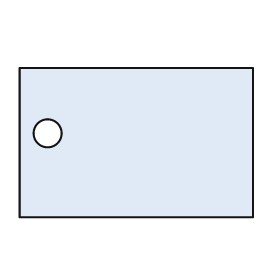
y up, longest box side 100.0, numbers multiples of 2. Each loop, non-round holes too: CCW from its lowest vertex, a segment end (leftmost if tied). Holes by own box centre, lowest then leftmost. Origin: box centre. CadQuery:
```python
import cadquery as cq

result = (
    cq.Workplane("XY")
    .moveTo(-50.0, -32.0)
    .lineTo(50.0, -32.0)
    .lineTo(50.0, 32.0)
    .lineTo(-50.0, 32.0)
    .close()
    .moveTo(-38.0, 4.0)
    .circle(6.0)
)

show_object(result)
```